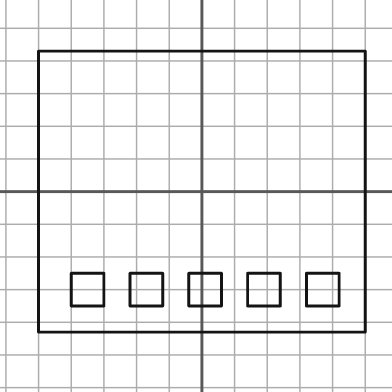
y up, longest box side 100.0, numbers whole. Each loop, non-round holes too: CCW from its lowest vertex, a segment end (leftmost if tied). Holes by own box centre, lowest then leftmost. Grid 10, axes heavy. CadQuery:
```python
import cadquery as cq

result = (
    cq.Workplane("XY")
    .moveTo(-50.0, -43.0)
    .lineTo(50.0, -43.0)
    .lineTo(50.0, 43.0)
    .lineTo(-50.0, 43.0)
    .close()
    .moveTo(-40.0, -35.0)
    .lineTo(-30.0, -35.0)
    .lineTo(-30.0, -25.0)
    .lineTo(-40.0, -25.0)
    .close()
    .moveTo(-22.0, -35.0)
    .lineTo(-12.0, -35.0)
    .lineTo(-12.0, -25.0)
    .lineTo(-22.0, -25.0)
    .close()
    .moveTo(-4.0, -35.0)
    .lineTo(6.0, -35.0)
    .lineTo(6.0, -25.0)
    .lineTo(-4.0, -25.0)
    .close()
    .moveTo(14.0, -35.0)
    .lineTo(24.0, -35.0)
    .lineTo(24.0, -25.0)
    .lineTo(14.0, -25.0)
    .close()
    .moveTo(32.0, -35.0)
    .lineTo(42.0, -35.0)
    .lineTo(42.0, -25.0)
    .lineTo(32.0, -25.0)
    .close()
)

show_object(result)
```